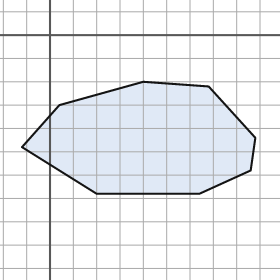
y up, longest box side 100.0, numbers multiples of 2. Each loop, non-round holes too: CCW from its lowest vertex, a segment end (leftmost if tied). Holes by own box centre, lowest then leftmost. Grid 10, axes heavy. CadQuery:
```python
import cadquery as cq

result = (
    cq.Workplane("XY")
    .moveTo(20.0, -68.0)
    .lineTo(64.0, -68.0)
    .lineTo(86.0, -58.0)
    .lineTo(88.0, -44.0)
    .lineTo(68.0, -22.0)
    .lineTo(40.0, -20.0)
    .lineTo(4.0, -30.0)
    .lineTo(-12.0, -48.0)
    .close()
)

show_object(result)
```